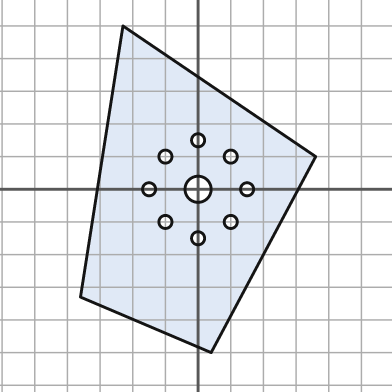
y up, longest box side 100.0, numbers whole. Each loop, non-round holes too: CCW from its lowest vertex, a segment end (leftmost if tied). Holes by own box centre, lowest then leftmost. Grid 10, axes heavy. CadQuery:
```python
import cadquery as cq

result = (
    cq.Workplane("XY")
    .moveTo(4.0, -50.0)
    .lineTo(36.0, 10.0)
    .lineTo(-23.0, 50.0)
    .lineTo(-36.0, -33.0)
    .close()
    .moveTo(0.0, -15.0)
    .circle(2.0)
    .moveTo(-10.0, -10.0)
    .circle(2.0)
    .moveTo(10.0, -10.0)
    .circle(2.0)
    .moveTo(-15.0, 0.0)
    .circle(2.0)
    .moveTo(0.0, 0.0)
    .circle(4.0)
    .moveTo(15.0, 0.0)
    .circle(2.0)
    .moveTo(-10.0, 10.0)
    .circle(2.0)
    .moveTo(10.0, 10.0)
    .circle(2.0)
    .moveTo(0.0, 15.0)
    .circle(2.0)
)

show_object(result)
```